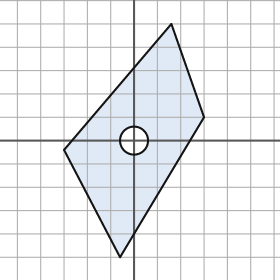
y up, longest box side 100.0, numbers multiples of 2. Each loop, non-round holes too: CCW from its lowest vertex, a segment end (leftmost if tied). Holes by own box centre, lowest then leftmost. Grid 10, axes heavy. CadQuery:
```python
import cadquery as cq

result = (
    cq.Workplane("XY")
    .moveTo(-6.0, -50.0)
    .lineTo(30.0, 10.0)
    .lineTo(16.0, 50.0)
    .lineTo(-30.0, -4.0)
    .close()
    .moveTo(0.0, 0.0)
    .circle(6.0)
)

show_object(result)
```